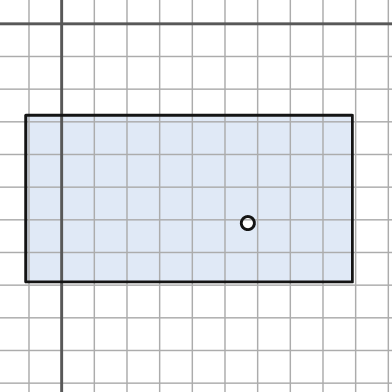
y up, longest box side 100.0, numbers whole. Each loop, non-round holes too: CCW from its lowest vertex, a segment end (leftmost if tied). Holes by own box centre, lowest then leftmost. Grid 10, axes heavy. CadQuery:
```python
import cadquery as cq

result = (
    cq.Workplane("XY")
    .moveTo(-11.0, -79.0)
    .lineTo(89.0, -79.0)
    .lineTo(89.0, -28.0)
    .lineTo(-11.0, -28.0)
    .close()
    .moveTo(57.0, -61.0)
    .circle(2.0)
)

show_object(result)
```